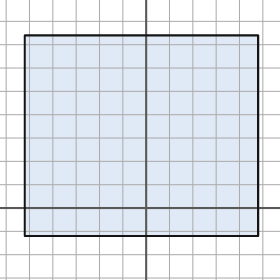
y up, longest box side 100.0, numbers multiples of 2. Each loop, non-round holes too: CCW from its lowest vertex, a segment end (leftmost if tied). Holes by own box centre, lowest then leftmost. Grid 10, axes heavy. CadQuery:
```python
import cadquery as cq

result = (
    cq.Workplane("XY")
    .moveTo(-52.0, -12.0)
    .lineTo(48.0, -12.0)
    .lineTo(48.0, 74.0)
    .lineTo(-52.0, 74.0)
    .close()
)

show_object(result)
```